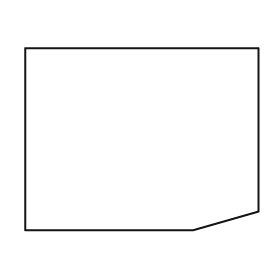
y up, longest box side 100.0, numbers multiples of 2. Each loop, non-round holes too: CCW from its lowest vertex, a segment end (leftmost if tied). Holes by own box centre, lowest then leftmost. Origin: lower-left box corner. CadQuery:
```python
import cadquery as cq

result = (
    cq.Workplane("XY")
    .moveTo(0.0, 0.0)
    .lineTo(72.0, 0.0)
    .lineTo(100.0, 8.0)
    .lineTo(100.0, 78.0)
    .lineTo(0.0, 78.0)
    .close()
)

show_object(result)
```